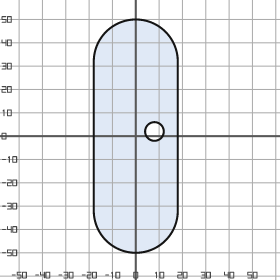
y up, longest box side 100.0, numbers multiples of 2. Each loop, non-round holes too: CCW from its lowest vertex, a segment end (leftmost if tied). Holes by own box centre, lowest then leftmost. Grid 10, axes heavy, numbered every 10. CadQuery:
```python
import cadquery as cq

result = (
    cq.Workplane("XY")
    .moveTo(-18.0, -32.0)
    .threePointArc((0.0, -50.0), (18.0, -32.0))
    .lineTo(18.0, 32.0)
    .threePointArc((0.0, 50.0), (-18.0, 32.0))
    .close()
    .moveTo(8.0, 2.0)
    .circle(4.0)
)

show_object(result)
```